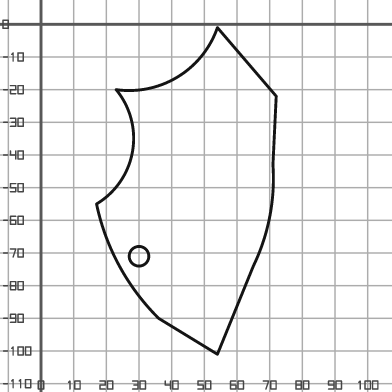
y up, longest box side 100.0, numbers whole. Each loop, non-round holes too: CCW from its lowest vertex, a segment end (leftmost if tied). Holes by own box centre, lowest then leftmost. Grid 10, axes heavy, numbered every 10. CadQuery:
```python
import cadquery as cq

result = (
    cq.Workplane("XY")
    .moveTo(54.0, -101.0)
    .lineTo(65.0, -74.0)
    .threePointArc((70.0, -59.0), (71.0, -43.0))
    .lineTo(72.0, -22.0)
    .lineTo(54.0, -1.0)
    .threePointArc((42.0, -16.0), (23.0, -20.0))
    .threePointArc((28.0, -39.0), (17.0, -55.0))
    .threePointArc((24.0, -74.0), (36.0, -90.0))
    .close()
    .moveTo(30.0, -71.0)
    .circle(3.0)
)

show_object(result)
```